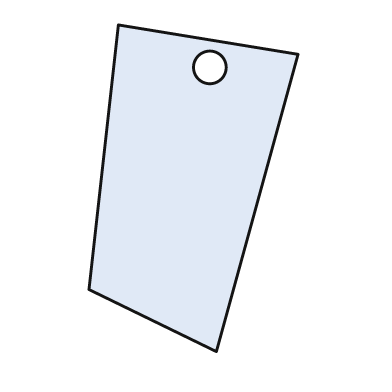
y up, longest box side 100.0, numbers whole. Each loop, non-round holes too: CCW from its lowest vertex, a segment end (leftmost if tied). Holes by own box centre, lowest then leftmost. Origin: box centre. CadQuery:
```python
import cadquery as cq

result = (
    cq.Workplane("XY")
    .moveTo(7.0, -50.0)
    .lineTo(32.0, 41.0)
    .lineTo(-23.0, 50.0)
    .lineTo(-32.0, -31.0)
    .close()
    .moveTo(5.0, 37.0)
    .circle(5.0)
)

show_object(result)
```